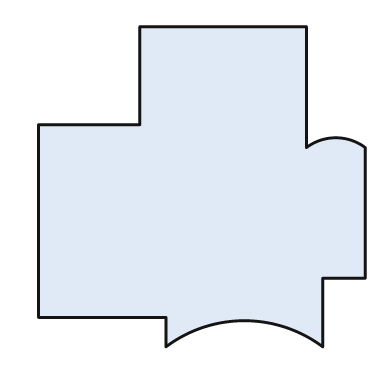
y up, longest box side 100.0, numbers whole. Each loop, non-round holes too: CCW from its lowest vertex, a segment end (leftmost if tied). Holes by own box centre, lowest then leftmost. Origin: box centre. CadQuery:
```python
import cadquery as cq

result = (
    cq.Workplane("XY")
    .moveTo(-11.0, -49.0)
    .threePointArc((13.0, -41.0), (37.0, -49.0))
    .lineTo(37.0, -28.0)
    .lineTo(50.0, -28.0)
    .lineTo(50.0, 12.0)
    .threePointArc((41.0, 15.0), (32.0, 12.0))
    .lineTo(32.0, 49.0)
    .lineTo(-19.0, 49.0)
    .lineTo(-19.0, 19.0)
    .lineTo(-50.0, 19.0)
    .lineTo(-50.0, -40.0)
    .lineTo(-11.0, -40.0)
    .close()
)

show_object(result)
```